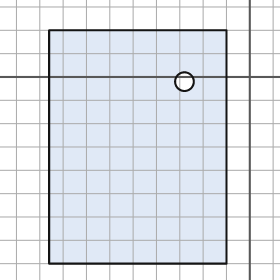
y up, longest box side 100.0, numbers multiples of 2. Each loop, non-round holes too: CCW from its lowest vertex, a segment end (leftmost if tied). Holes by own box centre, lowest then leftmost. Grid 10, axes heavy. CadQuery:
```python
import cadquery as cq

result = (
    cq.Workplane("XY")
    .moveTo(-86.0, -80.0)
    .lineTo(-10.0, -80.0)
    .lineTo(-10.0, 20.0)
    .lineTo(-86.0, 20.0)
    .close()
    .moveTo(-28.0, -2.0)
    .circle(4.0)
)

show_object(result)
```